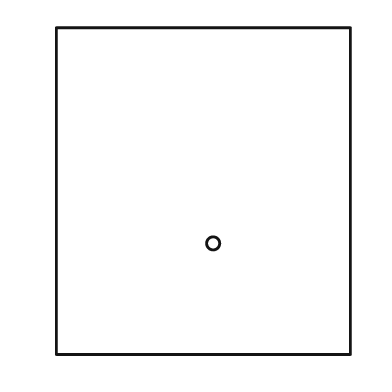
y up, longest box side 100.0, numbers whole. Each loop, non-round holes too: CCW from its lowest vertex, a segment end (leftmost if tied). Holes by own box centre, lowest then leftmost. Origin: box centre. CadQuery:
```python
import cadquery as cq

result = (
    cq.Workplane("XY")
    .moveTo(-45.0, -50.0)
    .lineTo(45.0, -50.0)
    .lineTo(45.0, 50.0)
    .lineTo(-45.0, 50.0)
    .close()
    .moveTo(3.0, -16.0)
    .circle(2.0)
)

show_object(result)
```